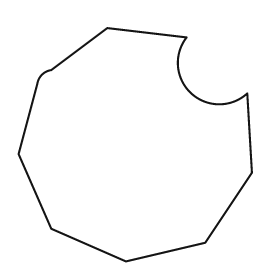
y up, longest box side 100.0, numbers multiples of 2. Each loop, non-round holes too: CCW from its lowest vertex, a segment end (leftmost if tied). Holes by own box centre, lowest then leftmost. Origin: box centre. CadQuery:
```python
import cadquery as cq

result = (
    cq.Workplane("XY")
    .moveTo(-4.0, -50.0)
    .lineTo(30.0, -42.0)
    .lineTo(50.0, -12.0)
    .lineTo(48.0, 22.0)
    .threePointArc((24.0, 22.0), (22.0, 46.0))
    .lineTo(-12.0, 50.0)
    .lineTo(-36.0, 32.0)
    .threePointArc((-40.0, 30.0), (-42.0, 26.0))
    .lineTo(-50.0, -4.0)
    .lineTo(-36.0, -36.0)
    .close()
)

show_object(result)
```